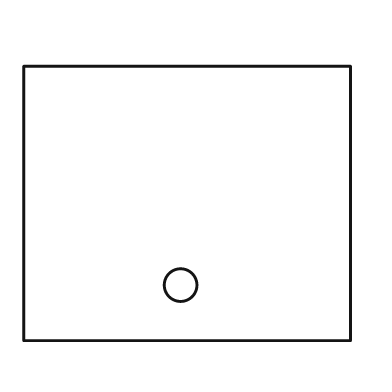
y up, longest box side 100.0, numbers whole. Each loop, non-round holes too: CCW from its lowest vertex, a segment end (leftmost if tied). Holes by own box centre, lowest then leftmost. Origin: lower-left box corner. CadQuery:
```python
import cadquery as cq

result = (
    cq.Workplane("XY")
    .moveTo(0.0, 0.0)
    .lineTo(100.0, 0.0)
    .lineTo(100.0, 84.0)
    .lineTo(0.0, 84.0)
    .close()
    .moveTo(48.0, 17.0)
    .circle(5.0)
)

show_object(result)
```